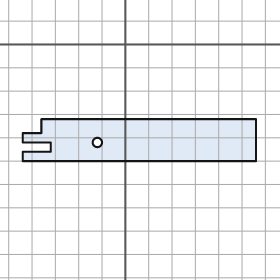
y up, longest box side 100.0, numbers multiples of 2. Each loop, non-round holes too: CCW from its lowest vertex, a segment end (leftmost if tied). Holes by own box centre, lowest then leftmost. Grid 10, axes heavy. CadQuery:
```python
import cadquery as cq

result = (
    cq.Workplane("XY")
    .moveTo(-44.0, -50.0)
    .lineTo(56.0, -50.0)
    .lineTo(56.0, -32.0)
    .lineTo(-36.0, -32.0)
    .lineTo(-36.0, -38.0)
    .lineTo(-44.0, -38.0)
    .lineTo(-44.0, -42.0)
    .lineTo(-32.0, -42.0)
    .lineTo(-32.0, -46.0)
    .lineTo(-44.0, -46.0)
    .close()
    .moveTo(-12.0, -42.0)
    .circle(2.0)
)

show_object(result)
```